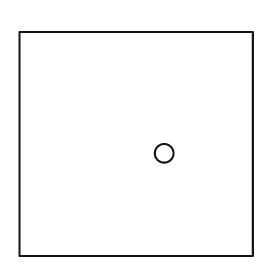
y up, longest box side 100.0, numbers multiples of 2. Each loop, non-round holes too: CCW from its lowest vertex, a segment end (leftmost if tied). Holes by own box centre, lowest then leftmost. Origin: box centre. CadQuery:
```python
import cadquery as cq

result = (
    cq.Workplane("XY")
    .moveTo(-50.0, -48.0)
    .lineTo(50.0, -48.0)
    .lineTo(50.0, 48.0)
    .lineTo(-50.0, 48.0)
    .close()
    .moveTo(12.0, -4.0)
    .circle(4.0)
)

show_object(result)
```